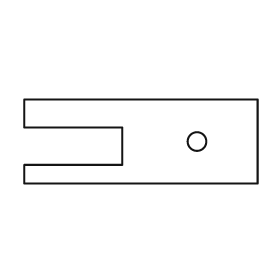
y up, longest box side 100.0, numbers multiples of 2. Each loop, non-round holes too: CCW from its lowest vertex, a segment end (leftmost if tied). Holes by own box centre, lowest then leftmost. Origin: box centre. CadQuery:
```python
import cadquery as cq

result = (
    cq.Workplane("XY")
    .moveTo(-50.0, -18.0)
    .lineTo(50.0, -18.0)
    .lineTo(50.0, 18.0)
    .lineTo(-50.0, 18.0)
    .lineTo(-50.0, 6.0)
    .lineTo(-8.0, 6.0)
    .lineTo(-8.0, -10.0)
    .lineTo(-50.0, -10.0)
    .close()
    .moveTo(24.0, 0.0)
    .circle(4.0)
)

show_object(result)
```